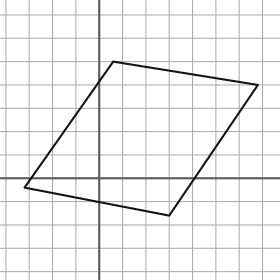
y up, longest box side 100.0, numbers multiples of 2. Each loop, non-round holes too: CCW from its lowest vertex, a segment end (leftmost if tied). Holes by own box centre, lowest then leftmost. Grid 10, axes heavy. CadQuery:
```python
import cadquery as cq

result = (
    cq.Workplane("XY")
    .moveTo(30.0, -16.0)
    .lineTo(68.0, 40.0)
    .lineTo(6.0, 50.0)
    .lineTo(-32.0, -4.0)
    .close()
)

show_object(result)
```